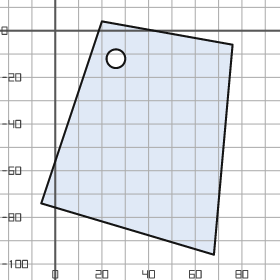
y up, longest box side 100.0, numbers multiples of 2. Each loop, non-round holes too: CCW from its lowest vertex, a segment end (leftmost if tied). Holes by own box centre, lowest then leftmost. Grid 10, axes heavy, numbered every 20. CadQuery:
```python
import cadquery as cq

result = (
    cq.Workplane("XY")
    .moveTo(68.0, -96.0)
    .lineTo(76.0, -6.0)
    .lineTo(20.0, 4.0)
    .lineTo(-6.0, -74.0)
    .close()
    .moveTo(26.0, -12.0)
    .circle(4.0)
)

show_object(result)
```